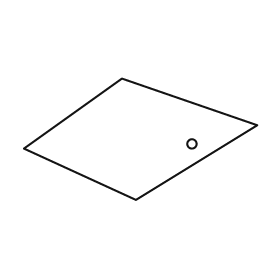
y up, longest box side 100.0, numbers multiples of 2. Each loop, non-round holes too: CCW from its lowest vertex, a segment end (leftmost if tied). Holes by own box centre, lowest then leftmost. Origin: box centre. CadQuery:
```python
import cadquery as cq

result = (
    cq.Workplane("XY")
    .moveTo(-2.0, -26.0)
    .lineTo(50.0, 6.0)
    .lineTo(-8.0, 26.0)
    .lineTo(-50.0, -4.0)
    .close()
    .moveTo(22.0, -2.0)
    .circle(2.0)
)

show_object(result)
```